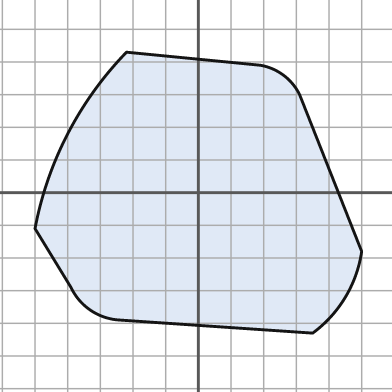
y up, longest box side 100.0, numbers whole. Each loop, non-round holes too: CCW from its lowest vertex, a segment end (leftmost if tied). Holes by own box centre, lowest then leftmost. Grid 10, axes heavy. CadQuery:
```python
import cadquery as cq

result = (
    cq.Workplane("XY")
    .moveTo(35.0, -43.0)
    .threePointArc((45.0, -32.0), (50.0, -18.0))
    .lineTo(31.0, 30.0)
    .threePointArc((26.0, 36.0), (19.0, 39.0))
    .lineTo(-22.0, 43.0)
    .threePointArc((-40.0, 18.0), (-50.0, -11.0))
    .lineTo(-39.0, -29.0)
    .threePointArc((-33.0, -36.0), (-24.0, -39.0))
    .close()
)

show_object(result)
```